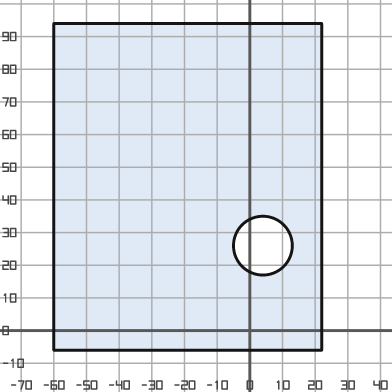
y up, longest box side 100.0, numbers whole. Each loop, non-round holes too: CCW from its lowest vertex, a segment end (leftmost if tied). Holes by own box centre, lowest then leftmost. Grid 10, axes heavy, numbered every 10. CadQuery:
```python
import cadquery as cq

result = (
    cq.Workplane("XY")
    .moveTo(-60.0, -6.0)
    .lineTo(22.0, -6.0)
    .lineTo(22.0, 94.0)
    .lineTo(-60.0, 94.0)
    .close()
    .moveTo(4.0, 26.0)
    .circle(9.0)
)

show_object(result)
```